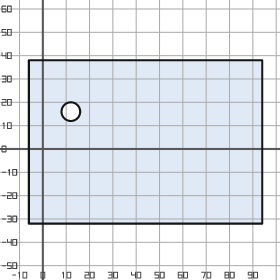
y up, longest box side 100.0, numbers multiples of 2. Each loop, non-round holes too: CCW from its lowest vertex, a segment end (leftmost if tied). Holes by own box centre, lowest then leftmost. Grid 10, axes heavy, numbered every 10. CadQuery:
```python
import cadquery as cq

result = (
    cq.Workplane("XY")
    .moveTo(-6.0, -32.0)
    .lineTo(94.0, -32.0)
    .lineTo(94.0, 38.0)
    .lineTo(-6.0, 38.0)
    .close()
    .moveTo(12.0, 16.0)
    .circle(4.0)
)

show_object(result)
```